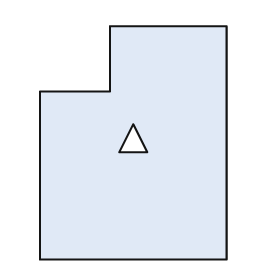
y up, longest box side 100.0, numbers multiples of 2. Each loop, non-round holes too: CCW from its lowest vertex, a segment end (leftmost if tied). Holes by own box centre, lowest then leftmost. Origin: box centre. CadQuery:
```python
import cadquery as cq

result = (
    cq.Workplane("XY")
    .moveTo(-40.0, -50.0)
    .lineTo(40.0, -50.0)
    .lineTo(40.0, 50.0)
    .lineTo(-10.0, 50.0)
    .lineTo(-10.0, 22.0)
    .lineTo(-40.0, 22.0)
    .close()
    .moveTo(-6.0, -4.0)
    .lineTo(6.0, -4.0)
    .lineTo(0.0, 8.0)
    .close()
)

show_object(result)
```